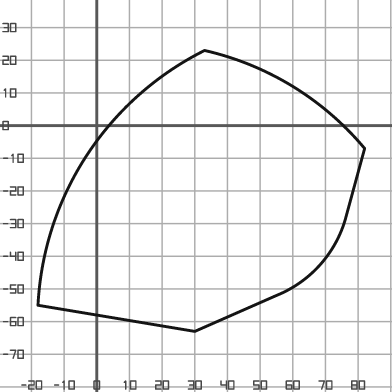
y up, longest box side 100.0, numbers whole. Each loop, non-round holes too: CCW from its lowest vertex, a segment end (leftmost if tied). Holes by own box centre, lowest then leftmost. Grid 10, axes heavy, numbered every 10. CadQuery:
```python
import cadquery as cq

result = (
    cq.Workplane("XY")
    .moveTo(30.0, -63.0)
    .lineTo(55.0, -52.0)
    .threePointArc((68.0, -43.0), (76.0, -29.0))
    .lineTo(82.0, -7.0)
    .threePointArc((60.0, 12.0), (33.0, 23.0))
    .threePointArc((-3.0, -9.0), (-18.0, -55.0))
    .close()
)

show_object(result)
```